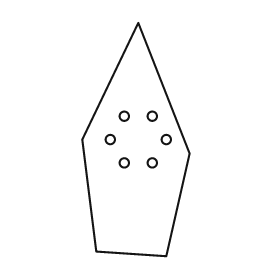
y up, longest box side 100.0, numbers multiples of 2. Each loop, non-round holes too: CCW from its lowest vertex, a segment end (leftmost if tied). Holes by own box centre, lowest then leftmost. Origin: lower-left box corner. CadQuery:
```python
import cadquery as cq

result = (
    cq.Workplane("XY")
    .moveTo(36.0, 0.0)
    .lineTo(46.0, 44.0)
    .lineTo(24.0, 100.0)
    .lineTo(0.0, 50.0)
    .lineTo(6.0, 2.0)
    .close()
    .moveTo(18.0, 40.0)
    .circle(2.0)
    .moveTo(30.0, 40.0)
    .circle(2.0)
    .moveTo(12.0, 50.0)
    .circle(2.0)
    .moveTo(36.0, 50.0)
    .circle(2.0)
    .moveTo(18.0, 60.0)
    .circle(2.0)
    .moveTo(30.0, 60.0)
    .circle(2.0)
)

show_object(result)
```